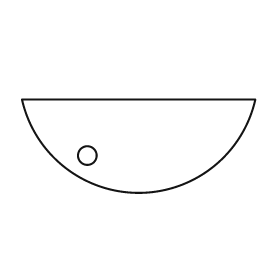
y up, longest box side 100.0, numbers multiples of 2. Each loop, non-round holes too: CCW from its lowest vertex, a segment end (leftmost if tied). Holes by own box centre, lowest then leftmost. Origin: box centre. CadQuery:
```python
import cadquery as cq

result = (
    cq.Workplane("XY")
    .moveTo(-50.0, 20.0)
    .threePointArc((0.0, -20.0), (50.0, 20.0))
    .close()
    .moveTo(-22.0, -4.0)
    .circle(4.0)
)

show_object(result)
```